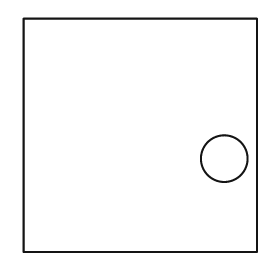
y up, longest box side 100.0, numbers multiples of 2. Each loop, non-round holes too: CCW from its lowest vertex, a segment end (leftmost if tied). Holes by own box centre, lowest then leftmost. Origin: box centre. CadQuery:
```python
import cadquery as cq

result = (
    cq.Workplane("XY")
    .moveTo(-50.0, -50.0)
    .lineTo(50.0, -50.0)
    .lineTo(50.0, 50.0)
    .lineTo(-50.0, 50.0)
    .close()
    .moveTo(36.0, -10.0)
    .circle(10.0)
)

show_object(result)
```